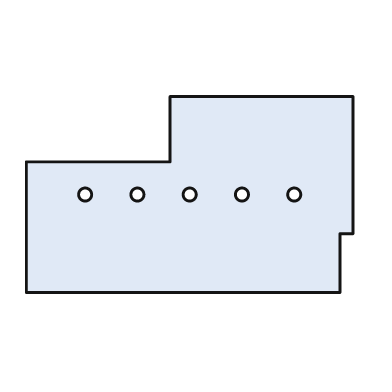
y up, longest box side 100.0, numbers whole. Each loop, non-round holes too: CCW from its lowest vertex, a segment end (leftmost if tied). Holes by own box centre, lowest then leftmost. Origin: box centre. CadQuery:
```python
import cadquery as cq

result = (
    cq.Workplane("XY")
    .moveTo(-50.0, -30.0)
    .lineTo(46.0, -30.0)
    .lineTo(46.0, -12.0)
    .lineTo(50.0, -12.0)
    .lineTo(50.0, 30.0)
    .lineTo(-6.0, 30.0)
    .lineTo(-6.0, 10.0)
    .lineTo(-50.0, 10.0)
    .close()
    .moveTo(-32.0, 0.0)
    .circle(2.0)
    .moveTo(-16.0, 0.0)
    .circle(2.0)
    .moveTo(0.0, 0.0)
    .circle(2.0)
    .moveTo(16.0, 0.0)
    .circle(2.0)
    .moveTo(32.0, 0.0)
    .circle(2.0)
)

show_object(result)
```